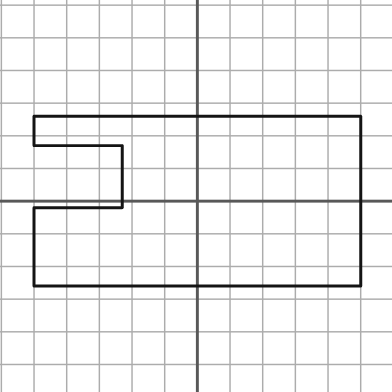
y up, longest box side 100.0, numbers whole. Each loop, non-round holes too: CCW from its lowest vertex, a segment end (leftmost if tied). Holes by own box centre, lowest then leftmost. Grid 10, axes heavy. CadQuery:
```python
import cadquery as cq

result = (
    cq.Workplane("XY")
    .moveTo(-50.0, -26.0)
    .lineTo(50.0, -26.0)
    .lineTo(50.0, 26.0)
    .lineTo(-50.0, 26.0)
    .lineTo(-50.0, 17.0)
    .lineTo(-23.0, 17.0)
    .lineTo(-23.0, -2.0)
    .lineTo(-50.0, -2.0)
    .close()
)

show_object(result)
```